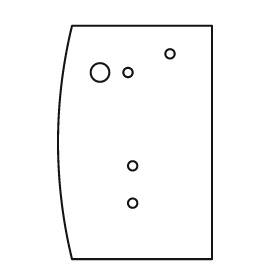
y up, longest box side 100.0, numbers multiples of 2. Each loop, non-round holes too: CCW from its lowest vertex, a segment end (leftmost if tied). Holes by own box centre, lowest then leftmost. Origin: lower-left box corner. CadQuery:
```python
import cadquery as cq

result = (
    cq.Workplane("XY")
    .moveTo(6.0, 0.0)
    .lineTo(66.0, 0.0)
    .lineTo(66.0, 100.0)
    .lineTo(6.0, 100.0)
    .threePointArc((0.0, 50.0), (6.0, 0.0))
    .close()
    .moveTo(32.0, 24.0)
    .circle(2.0)
    .moveTo(32.0, 40.0)
    .circle(2.0)
    .moveTo(18.0, 80.0)
    .circle(4.0)
    .moveTo(30.0, 80.0)
    .circle(2.0)
    .moveTo(48.0, 88.0)
    .circle(2.0)
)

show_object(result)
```